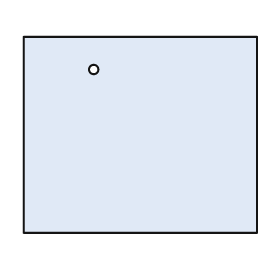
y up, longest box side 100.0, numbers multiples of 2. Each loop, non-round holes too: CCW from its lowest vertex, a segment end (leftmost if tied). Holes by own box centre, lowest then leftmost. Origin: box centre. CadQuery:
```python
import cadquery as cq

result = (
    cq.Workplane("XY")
    .moveTo(-50.0, -42.0)
    .lineTo(50.0, -42.0)
    .lineTo(50.0, 42.0)
    .lineTo(-50.0, 42.0)
    .close()
    .moveTo(-20.0, 28.0)
    .circle(2.0)
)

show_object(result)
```